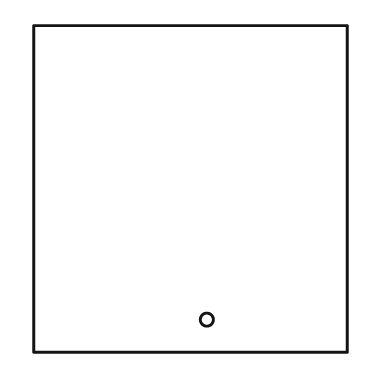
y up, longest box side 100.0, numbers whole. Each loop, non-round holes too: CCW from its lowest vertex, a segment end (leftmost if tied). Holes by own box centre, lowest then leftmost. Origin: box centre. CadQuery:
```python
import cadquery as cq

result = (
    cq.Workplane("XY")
    .moveTo(-48.0, -50.0)
    .lineTo(48.0, -50.0)
    .lineTo(48.0, 50.0)
    .lineTo(-48.0, 50.0)
    .close()
    .moveTo(5.0, -40.0)
    .circle(2.0)
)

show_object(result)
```